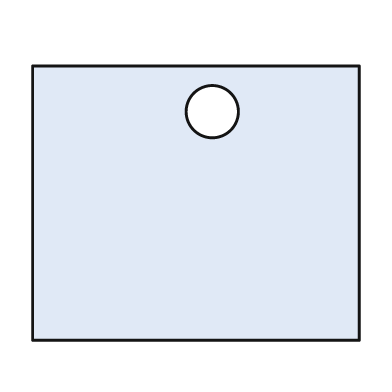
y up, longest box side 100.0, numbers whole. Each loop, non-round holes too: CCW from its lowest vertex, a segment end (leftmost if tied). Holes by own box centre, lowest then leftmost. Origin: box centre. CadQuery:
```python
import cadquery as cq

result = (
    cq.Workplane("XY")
    .moveTo(-50.0, -42.0)
    .lineTo(50.0, -42.0)
    .lineTo(50.0, 42.0)
    .lineTo(-50.0, 42.0)
    .close()
    .moveTo(5.0, 28.0)
    .circle(8.0)
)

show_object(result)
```